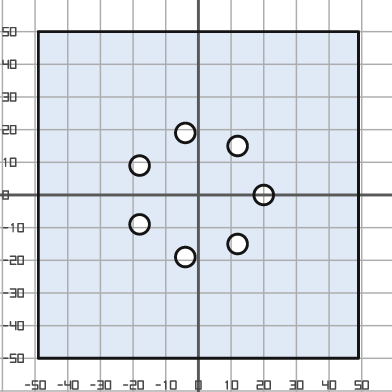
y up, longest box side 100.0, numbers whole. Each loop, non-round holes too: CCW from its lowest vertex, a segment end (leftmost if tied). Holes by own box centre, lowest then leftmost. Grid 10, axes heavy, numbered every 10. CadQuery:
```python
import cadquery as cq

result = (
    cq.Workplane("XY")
    .moveTo(-49.0, -50.0)
    .lineTo(49.0, -50.0)
    .lineTo(49.0, 50.0)
    .lineTo(-49.0, 50.0)
    .close()
    .moveTo(-4.0, -19.0)
    .circle(3.0)
    .moveTo(12.0, -15.0)
    .circle(3.0)
    .moveTo(-18.0, -9.0)
    .circle(3.0)
    .moveTo(20.0, 0.0)
    .circle(3.0)
    .moveTo(-18.0, 9.0)
    .circle(3.0)
    .moveTo(12.0, 15.0)
    .circle(3.0)
    .moveTo(-4.0, 19.0)
    .circle(3.0)
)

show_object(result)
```